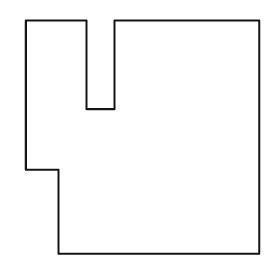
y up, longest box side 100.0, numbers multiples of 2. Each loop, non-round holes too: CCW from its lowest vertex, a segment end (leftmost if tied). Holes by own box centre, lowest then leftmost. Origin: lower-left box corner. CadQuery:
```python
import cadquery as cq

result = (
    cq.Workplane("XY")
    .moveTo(14.0, 0.0)
    .lineTo(100.0, 0.0)
    .lineTo(100.0, 100.0)
    .lineTo(38.0, 100.0)
    .lineTo(38.0, 62.0)
    .lineTo(26.0, 62.0)
    .lineTo(26.0, 100.0)
    .lineTo(0.0, 100.0)
    .lineTo(0.0, 36.0)
    .lineTo(14.0, 36.0)
    .close()
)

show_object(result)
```